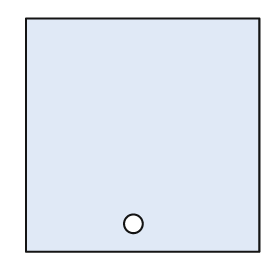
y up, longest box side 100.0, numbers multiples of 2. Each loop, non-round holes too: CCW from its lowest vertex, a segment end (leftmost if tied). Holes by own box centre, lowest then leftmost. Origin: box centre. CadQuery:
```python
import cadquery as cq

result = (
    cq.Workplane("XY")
    .moveTo(-50.0, -50.0)
    .lineTo(50.0, -50.0)
    .lineTo(50.0, 50.0)
    .lineTo(-50.0, 50.0)
    .close()
    .moveTo(-4.0, -38.0)
    .circle(4.0)
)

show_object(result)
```